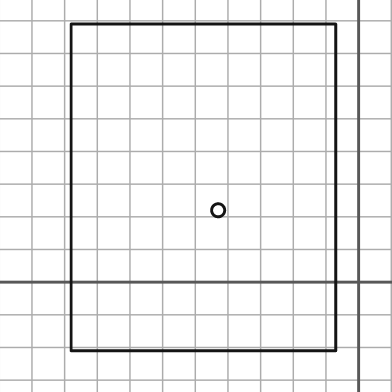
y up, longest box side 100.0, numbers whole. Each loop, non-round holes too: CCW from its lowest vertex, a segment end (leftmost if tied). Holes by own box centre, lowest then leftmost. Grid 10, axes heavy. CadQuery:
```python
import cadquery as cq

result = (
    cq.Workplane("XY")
    .moveTo(-88.0, -21.0)
    .lineTo(-7.0, -21.0)
    .lineTo(-7.0, 79.0)
    .lineTo(-88.0, 79.0)
    .close()
    .moveTo(-43.0, 22.0)
    .circle(2.0)
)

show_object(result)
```